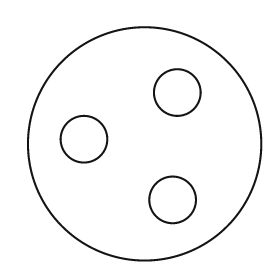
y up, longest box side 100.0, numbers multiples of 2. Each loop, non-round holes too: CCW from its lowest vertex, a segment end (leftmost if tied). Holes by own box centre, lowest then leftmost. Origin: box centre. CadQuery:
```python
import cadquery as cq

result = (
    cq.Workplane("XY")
    .moveTo(0.0, 0.0)
    .circle(50.0)
    .moveTo(12.0, -24.0)
    .circle(10.0)
    .moveTo(-26.0, 2.0)
    .circle(10.0)
    .moveTo(14.0, 22.0)
    .circle(10.0)
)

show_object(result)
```